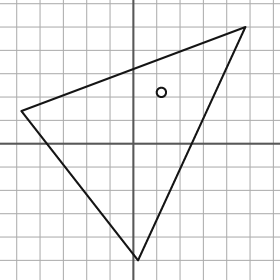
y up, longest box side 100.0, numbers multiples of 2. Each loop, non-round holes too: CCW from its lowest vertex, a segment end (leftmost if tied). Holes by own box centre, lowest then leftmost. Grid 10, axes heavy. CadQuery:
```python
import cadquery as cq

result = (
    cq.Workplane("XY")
    .moveTo(2.0, -50.0)
    .lineTo(48.0, 50.0)
    .lineTo(-48.0, 14.0)
    .close()
    .moveTo(12.0, 22.0)
    .circle(2.0)
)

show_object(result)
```